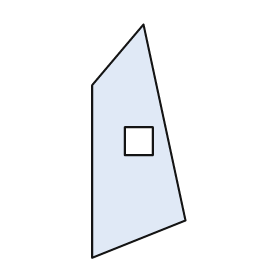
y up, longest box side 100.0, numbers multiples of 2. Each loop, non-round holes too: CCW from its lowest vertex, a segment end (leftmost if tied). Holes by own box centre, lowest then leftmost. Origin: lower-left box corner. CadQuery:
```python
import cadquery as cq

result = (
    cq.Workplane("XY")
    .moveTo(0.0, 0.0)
    .lineTo(40.0, 16.0)
    .lineTo(22.0, 100.0)
    .lineTo(0.0, 74.0)
    .close()
    .moveTo(14.0, 44.0)
    .lineTo(26.0, 44.0)
    .lineTo(26.0, 56.0)
    .lineTo(14.0, 56.0)
    .close()
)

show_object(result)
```